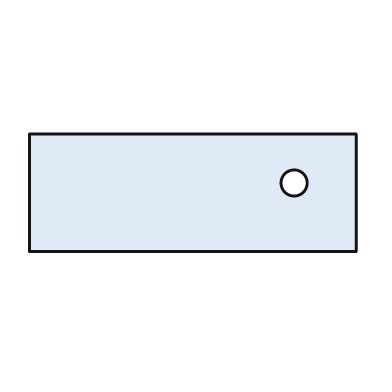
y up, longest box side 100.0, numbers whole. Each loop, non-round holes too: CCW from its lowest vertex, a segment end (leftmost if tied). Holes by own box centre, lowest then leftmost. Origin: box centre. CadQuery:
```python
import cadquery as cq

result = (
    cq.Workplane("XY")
    .moveTo(-50.0, -18.0)
    .lineTo(50.0, -18.0)
    .lineTo(50.0, 18.0)
    .lineTo(-50.0, 18.0)
    .close()
    .moveTo(31.0, 3.0)
    .circle(4.0)
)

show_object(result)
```